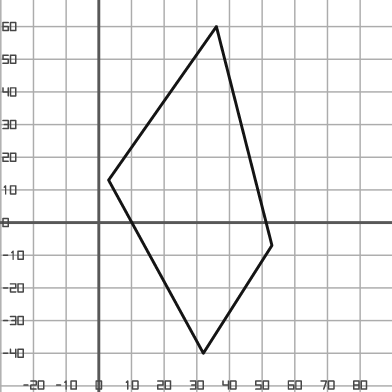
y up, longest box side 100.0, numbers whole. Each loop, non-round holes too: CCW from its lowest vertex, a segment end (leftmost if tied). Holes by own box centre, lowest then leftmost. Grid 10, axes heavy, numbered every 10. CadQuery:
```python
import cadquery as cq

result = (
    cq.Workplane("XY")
    .moveTo(32.0, -40.0)
    .lineTo(53.0, -7.0)
    .lineTo(36.0, 60.0)
    .lineTo(3.0, 13.0)
    .close()
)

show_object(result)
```